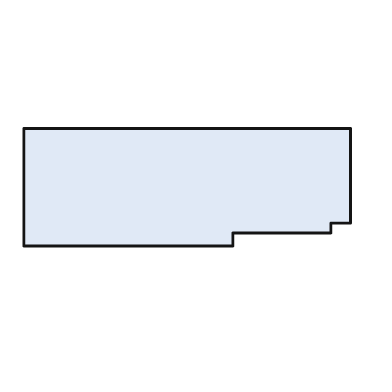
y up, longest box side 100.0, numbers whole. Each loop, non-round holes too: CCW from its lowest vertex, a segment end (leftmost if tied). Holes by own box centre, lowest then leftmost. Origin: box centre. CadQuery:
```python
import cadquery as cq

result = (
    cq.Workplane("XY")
    .moveTo(-50.0, -18.0)
    .lineTo(14.0, -18.0)
    .lineTo(14.0, -14.0)
    .lineTo(44.0, -14.0)
    .lineTo(44.0, -11.0)
    .lineTo(50.0, -11.0)
    .lineTo(50.0, 18.0)
    .lineTo(-50.0, 18.0)
    .close()
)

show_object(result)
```